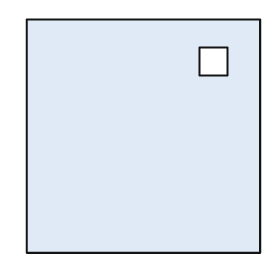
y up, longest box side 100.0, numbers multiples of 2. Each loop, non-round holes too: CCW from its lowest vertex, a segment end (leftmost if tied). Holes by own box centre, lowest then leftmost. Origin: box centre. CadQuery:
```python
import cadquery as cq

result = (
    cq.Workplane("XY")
    .moveTo(-50.0, -50.0)
    .lineTo(50.0, -50.0)
    .lineTo(50.0, 50.0)
    .lineTo(-50.0, 50.0)
    .close()
    .moveTo(24.0, 26.0)
    .lineTo(36.0, 26.0)
    .lineTo(36.0, 38.0)
    .lineTo(24.0, 38.0)
    .close()
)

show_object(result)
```